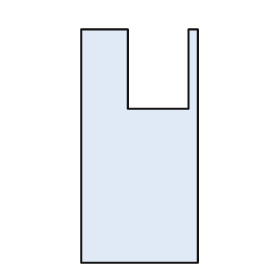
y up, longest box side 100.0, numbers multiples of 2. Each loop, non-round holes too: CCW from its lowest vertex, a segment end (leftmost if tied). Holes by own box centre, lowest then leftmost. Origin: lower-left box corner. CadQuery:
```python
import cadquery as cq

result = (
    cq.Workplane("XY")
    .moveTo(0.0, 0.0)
    .lineTo(50.0, 0.0)
    .lineTo(50.0, 100.0)
    .lineTo(46.0, 100.0)
    .lineTo(46.0, 66.0)
    .lineTo(20.0, 66.0)
    .lineTo(20.0, 100.0)
    .lineTo(0.0, 100.0)
    .close()
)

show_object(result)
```